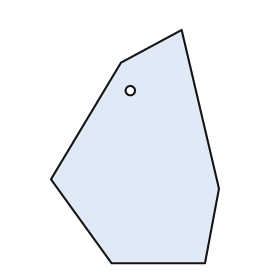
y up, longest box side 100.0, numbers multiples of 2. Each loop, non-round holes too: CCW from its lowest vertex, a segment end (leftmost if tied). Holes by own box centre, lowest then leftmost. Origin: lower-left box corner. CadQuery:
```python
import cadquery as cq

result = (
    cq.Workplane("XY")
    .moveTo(26.0, 0.0)
    .lineTo(66.0, 0.0)
    .lineTo(72.0, 32.0)
    .lineTo(56.0, 100.0)
    .lineTo(30.0, 86.0)
    .lineTo(0.0, 36.0)
    .close()
    .moveTo(34.0, 74.0)
    .circle(2.0)
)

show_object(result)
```